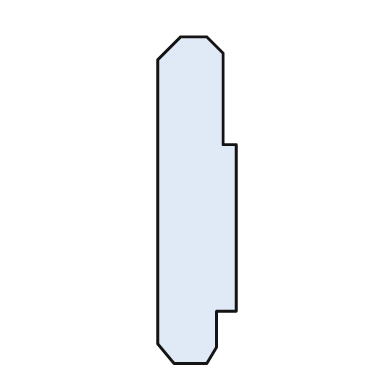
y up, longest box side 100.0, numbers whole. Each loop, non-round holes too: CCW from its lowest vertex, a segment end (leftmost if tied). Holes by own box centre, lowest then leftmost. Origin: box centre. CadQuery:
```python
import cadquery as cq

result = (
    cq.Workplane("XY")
    .moveTo(-7.0, -50.0)
    .lineTo(3.0, -50.0)
    .lineTo(6.0, -45.0)
    .lineTo(6.0, -34.0)
    .lineTo(12.0, -34.0)
    .lineTo(12.0, 17.0)
    .lineTo(8.0, 17.0)
    .lineTo(8.0, 45.0)
    .lineTo(3.0, 50.0)
    .lineTo(-5.0, 50.0)
    .lineTo(-12.0, 43.0)
    .lineTo(-12.0, -44.0)
    .close()
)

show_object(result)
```